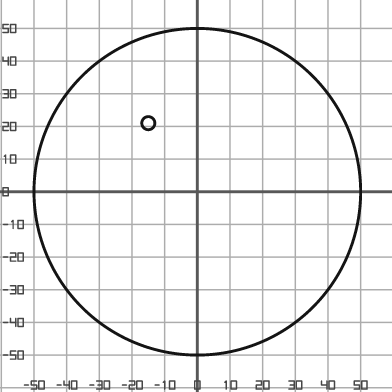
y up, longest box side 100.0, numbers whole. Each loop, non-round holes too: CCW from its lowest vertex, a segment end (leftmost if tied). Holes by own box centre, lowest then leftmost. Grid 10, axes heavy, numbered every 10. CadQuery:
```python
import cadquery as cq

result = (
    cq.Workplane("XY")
    .moveTo(0.0, 0.0)
    .circle(50.0)
    .moveTo(-15.0, 21.0)
    .circle(2.0)
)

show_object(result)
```